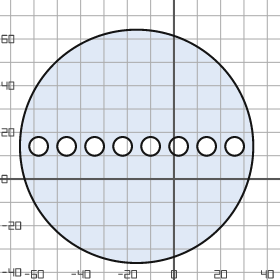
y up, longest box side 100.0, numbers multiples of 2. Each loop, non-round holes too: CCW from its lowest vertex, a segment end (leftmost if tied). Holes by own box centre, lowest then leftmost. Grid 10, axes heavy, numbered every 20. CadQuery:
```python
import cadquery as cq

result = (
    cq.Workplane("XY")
    .moveTo(-16.0, 14.0)
    .circle(50.0)
    .moveTo(-58.0, 14.0)
    .circle(4.0)
    .moveTo(-46.0, 14.0)
    .circle(4.0)
    .moveTo(-34.0, 14.0)
    .circle(4.0)
    .moveTo(-22.0, 14.0)
    .circle(4.0)
    .moveTo(-10.0, 14.0)
    .circle(4.0)
    .moveTo(2.0, 14.0)
    .circle(4.0)
    .moveTo(14.0, 14.0)
    .circle(4.0)
    .moveTo(26.0, 14.0)
    .circle(4.0)
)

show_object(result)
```